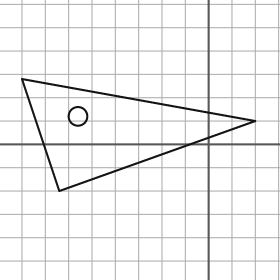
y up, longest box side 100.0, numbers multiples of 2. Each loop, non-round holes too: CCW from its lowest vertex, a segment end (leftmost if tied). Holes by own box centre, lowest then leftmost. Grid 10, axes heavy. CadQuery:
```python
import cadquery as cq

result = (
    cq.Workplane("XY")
    .moveTo(-64.0, -20.0)
    .lineTo(20.0, 10.0)
    .lineTo(-80.0, 28.0)
    .close()
    .moveTo(-56.0, 12.0)
    .circle(4.0)
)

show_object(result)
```